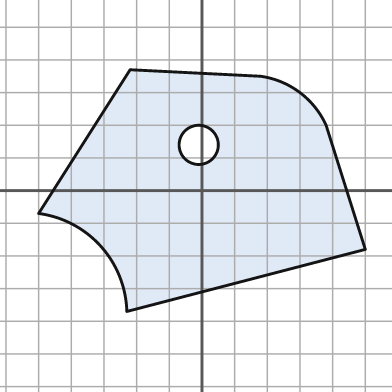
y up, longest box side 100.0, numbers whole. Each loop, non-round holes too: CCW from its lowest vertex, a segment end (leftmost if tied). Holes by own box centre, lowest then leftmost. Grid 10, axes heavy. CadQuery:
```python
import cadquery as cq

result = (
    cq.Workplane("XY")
    .moveTo(-23.0, -37.0)
    .lineTo(50.0, -18.0)
    .lineTo(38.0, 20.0)
    .threePointArc((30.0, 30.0), (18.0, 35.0))
    .lineTo(-22.0, 37.0)
    .lineTo(-50.0, -7.0)
    .threePointArc((-31.0, -17.0), (-23.0, -37.0))
    .close()
    .moveTo(-1.0, 14.0)
    .circle(6.0)
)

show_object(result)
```